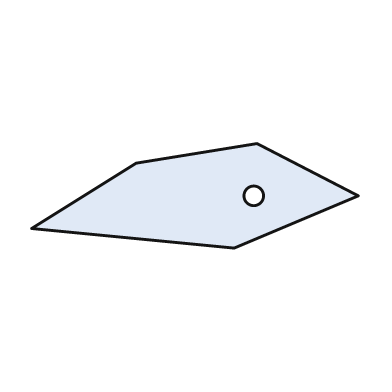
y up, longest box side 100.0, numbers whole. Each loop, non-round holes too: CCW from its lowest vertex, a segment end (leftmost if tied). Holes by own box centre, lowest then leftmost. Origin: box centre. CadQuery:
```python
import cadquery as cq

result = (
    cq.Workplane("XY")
    .moveTo(12.0, -16.0)
    .lineTo(50.0, 0.0)
    .lineTo(19.0, 16.0)
    .lineTo(-18.0, 10.0)
    .lineTo(-50.0, -10.0)
    .close()
    .moveTo(18.0, 0.0)
    .circle(3.0)
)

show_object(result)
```